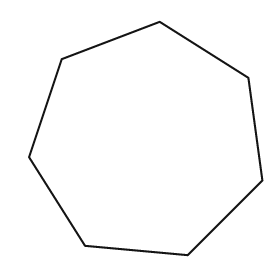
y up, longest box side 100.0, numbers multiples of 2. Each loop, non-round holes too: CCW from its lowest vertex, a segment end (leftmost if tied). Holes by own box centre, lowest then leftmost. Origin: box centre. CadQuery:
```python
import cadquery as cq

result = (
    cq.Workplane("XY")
    .moveTo(18.0, -50.0)
    .lineTo(50.0, -18.0)
    .lineTo(44.0, 26.0)
    .lineTo(6.0, 50.0)
    .lineTo(-36.0, 34.0)
    .lineTo(-50.0, -8.0)
    .lineTo(-26.0, -46.0)
    .close()
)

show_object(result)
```